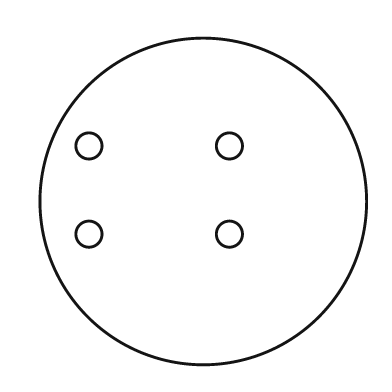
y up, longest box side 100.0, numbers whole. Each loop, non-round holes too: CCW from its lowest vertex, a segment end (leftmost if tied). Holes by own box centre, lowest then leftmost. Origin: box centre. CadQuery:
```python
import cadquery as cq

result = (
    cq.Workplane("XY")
    .moveTo(0.0, 0.0)
    .circle(50.0)
    .moveTo(-35.0, -10.0)
    .circle(4.0)
    .moveTo(8.0, -10.0)
    .circle(4.0)
    .moveTo(-35.0, 17.0)
    .circle(4.0)
    .moveTo(8.0, 17.0)
    .circle(4.0)
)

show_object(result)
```